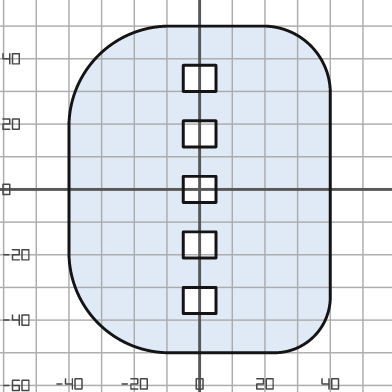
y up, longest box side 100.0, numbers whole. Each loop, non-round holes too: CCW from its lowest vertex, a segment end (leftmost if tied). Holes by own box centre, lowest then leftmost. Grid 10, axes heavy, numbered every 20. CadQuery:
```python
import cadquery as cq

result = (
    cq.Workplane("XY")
    .moveTo(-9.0, -50.0)
    .lineTo(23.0, -50.0)
    .threePointArc((35.0, -45.0), (40.0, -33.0))
    .lineTo(40.0, 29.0)
    .threePointArc((34.0, 44.0), (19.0, 50.0))
    .lineTo(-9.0, 50.0)
    .threePointArc((-31.0, 41.0), (-40.0, 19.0))
    .lineTo(-40.0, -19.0)
    .threePointArc((-31.0, -41.0), (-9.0, -50.0))
    .close()
    .moveTo(-5.0, -38.0)
    .lineTo(5.0, -38.0)
    .lineTo(5.0, -30.0)
    .lineTo(-5.0, -30.0)
    .close()
    .moveTo(-5.0, -21.0)
    .lineTo(5.0, -21.0)
    .lineTo(5.0, -13.0)
    .lineTo(-5.0, -13.0)
    .close()
    .moveTo(-5.0, -4.0)
    .lineTo(5.0, -4.0)
    .lineTo(5.0, 4.0)
    .lineTo(-5.0, 4.0)
    .close()
    .moveTo(-5.0, 13.0)
    .lineTo(5.0, 13.0)
    .lineTo(5.0, 21.0)
    .lineTo(-5.0, 21.0)
    .close()
    .moveTo(-5.0, 30.0)
    .lineTo(5.0, 30.0)
    .lineTo(5.0, 38.0)
    .lineTo(-5.0, 38.0)
    .close()
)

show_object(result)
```